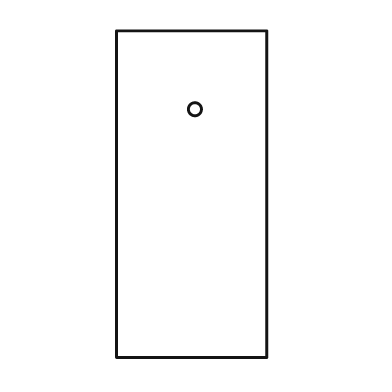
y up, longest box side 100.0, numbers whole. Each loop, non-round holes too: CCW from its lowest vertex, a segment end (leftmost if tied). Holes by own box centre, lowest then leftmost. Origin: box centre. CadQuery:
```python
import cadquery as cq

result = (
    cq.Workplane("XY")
    .moveTo(-23.0, -50.0)
    .lineTo(23.0, -50.0)
    .lineTo(23.0, 50.0)
    .lineTo(-23.0, 50.0)
    .close()
    .moveTo(1.0, 26.0)
    .circle(2.0)
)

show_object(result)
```